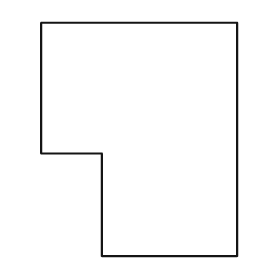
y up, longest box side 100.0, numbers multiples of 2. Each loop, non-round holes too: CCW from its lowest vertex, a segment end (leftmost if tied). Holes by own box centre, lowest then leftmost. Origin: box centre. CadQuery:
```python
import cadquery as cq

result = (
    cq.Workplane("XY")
    .moveTo(-16.0, -50.0)
    .lineTo(42.0, -50.0)
    .lineTo(42.0, 50.0)
    .lineTo(-42.0, 50.0)
    .lineTo(-42.0, -6.0)
    .lineTo(-16.0, -6.0)
    .close()
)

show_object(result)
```